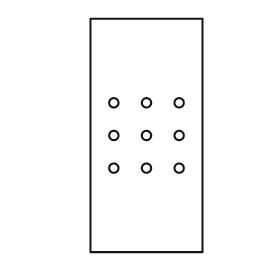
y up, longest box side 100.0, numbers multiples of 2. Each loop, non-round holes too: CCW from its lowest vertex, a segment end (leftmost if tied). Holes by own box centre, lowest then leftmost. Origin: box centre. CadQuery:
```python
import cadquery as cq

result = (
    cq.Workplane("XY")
    .moveTo(-24.0, -50.0)
    .lineTo(24.0, -50.0)
    .lineTo(24.0, 50.0)
    .lineTo(-24.0, 50.0)
    .close()
    .moveTo(-14.0, -14.0)
    .circle(2.0)
    .moveTo(0.0, -14.0)
    .circle(2.0)
    .moveTo(14.0, -14.0)
    .circle(2.0)
    .moveTo(-14.0, 0.0)
    .circle(2.0)
    .moveTo(0.0, 0.0)
    .circle(2.0)
    .moveTo(14.0, 0.0)
    .circle(2.0)
    .moveTo(-14.0, 14.0)
    .circle(2.0)
    .moveTo(0.0, 14.0)
    .circle(2.0)
    .moveTo(14.0, 14.0)
    .circle(2.0)
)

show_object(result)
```